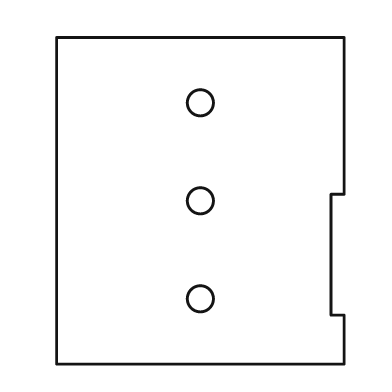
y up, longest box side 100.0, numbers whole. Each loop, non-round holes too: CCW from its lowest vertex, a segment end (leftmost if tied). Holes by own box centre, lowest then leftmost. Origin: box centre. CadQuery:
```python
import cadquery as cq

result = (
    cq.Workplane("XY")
    .moveTo(-44.0, -50.0)
    .lineTo(44.0, -50.0)
    .lineTo(44.0, -35.0)
    .lineTo(40.0, -35.0)
    .lineTo(40.0, 2.0)
    .lineTo(44.0, 2.0)
    .lineTo(44.0, 50.0)
    .lineTo(-44.0, 50.0)
    .close()
    .moveTo(0.0, -30.0)
    .circle(4.0)
    .moveTo(0.0, 0.0)
    .circle(4.0)
    .moveTo(0.0, 30.0)
    .circle(4.0)
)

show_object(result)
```